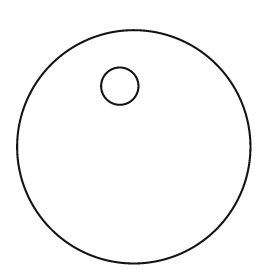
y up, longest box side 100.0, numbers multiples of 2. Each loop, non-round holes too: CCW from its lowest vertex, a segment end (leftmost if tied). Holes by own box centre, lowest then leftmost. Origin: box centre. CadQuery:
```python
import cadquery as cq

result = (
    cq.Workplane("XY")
    .moveTo(0.0, 0.0)
    .circle(50.0)
    .moveTo(-6.0, 26.0)
    .circle(8.0)
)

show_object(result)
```